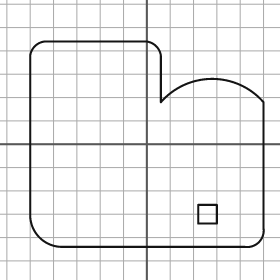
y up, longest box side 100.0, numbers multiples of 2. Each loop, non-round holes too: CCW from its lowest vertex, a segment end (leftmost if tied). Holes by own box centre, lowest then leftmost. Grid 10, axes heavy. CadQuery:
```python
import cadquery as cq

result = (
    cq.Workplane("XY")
    .moveTo(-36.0, -44.0)
    .lineTo(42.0, -44.0)
    .threePointArc((48.0, -42.0), (50.0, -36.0))
    .lineTo(50.0, 18.0)
    .threePointArc((28.0, 28.0), (6.0, 18.0))
    .lineTo(6.0, 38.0)
    .threePointArc((4.0, 42.0), (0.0, 44.0))
    .lineTo(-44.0, 44.0)
    .threePointArc((-48.0, 42.0), (-50.0, 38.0))
    .lineTo(-50.0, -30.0)
    .threePointArc((-46.0, -40.0), (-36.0, -44.0))
    .close()
    .moveTo(22.0, -34.0)
    .lineTo(30.0, -34.0)
    .lineTo(30.0, -26.0)
    .lineTo(22.0, -26.0)
    .close()
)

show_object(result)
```